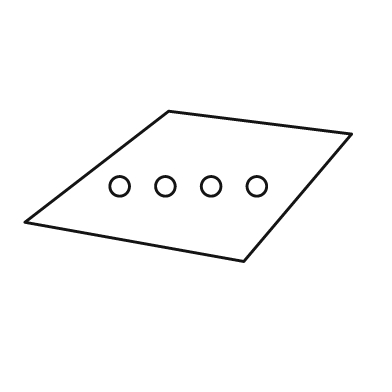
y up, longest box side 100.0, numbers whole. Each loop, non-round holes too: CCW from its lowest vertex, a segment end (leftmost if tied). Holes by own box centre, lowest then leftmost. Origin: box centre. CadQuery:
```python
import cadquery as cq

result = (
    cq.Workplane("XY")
    .moveTo(17.0, -23.0)
    .lineTo(50.0, 16.0)
    .lineTo(-6.0, 23.0)
    .lineTo(-50.0, -11.0)
    .close()
    .moveTo(-21.0, 0.0)
    .circle(3.0)
    .moveTo(-7.0, 0.0)
    .circle(3.0)
    .moveTo(7.0, 0.0)
    .circle(3.0)
    .moveTo(21.0, 0.0)
    .circle(3.0)
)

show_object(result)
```